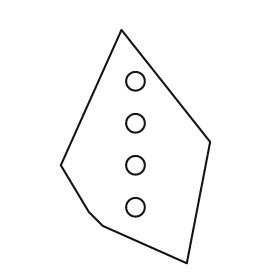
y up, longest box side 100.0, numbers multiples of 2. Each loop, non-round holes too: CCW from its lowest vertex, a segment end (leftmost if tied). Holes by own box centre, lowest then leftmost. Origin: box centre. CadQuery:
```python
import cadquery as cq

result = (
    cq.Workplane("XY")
    .moveTo(22.0, -50.0)
    .lineTo(32.0, 2.0)
    .lineTo(-6.0, 50.0)
    .lineTo(-32.0, -8.0)
    .lineTo(-20.0, -28.0)
    .lineTo(-14.0, -34.0)
    .close()
    .moveTo(0.0, -26.0)
    .circle(4.0)
    .moveTo(0.0, -8.0)
    .circle(4.0)
    .moveTo(0.0, 10.0)
    .circle(4.0)
    .moveTo(0.0, 28.0)
    .circle(4.0)
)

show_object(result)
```